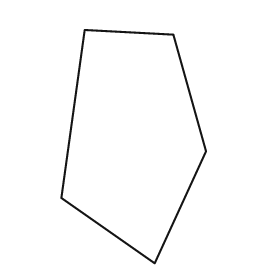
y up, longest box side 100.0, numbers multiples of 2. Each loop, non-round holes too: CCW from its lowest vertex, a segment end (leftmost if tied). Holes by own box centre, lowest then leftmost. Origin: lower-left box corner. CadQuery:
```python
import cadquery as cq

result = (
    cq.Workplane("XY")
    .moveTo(40.0, 0.0)
    .lineTo(62.0, 48.0)
    .lineTo(48.0, 98.0)
    .lineTo(10.0, 100.0)
    .lineTo(0.0, 28.0)
    .close()
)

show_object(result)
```